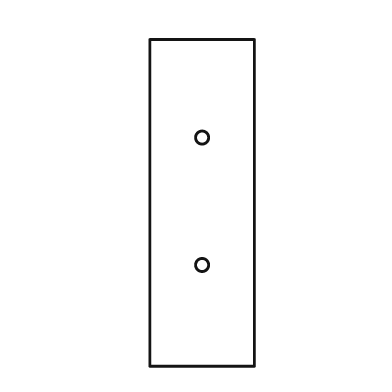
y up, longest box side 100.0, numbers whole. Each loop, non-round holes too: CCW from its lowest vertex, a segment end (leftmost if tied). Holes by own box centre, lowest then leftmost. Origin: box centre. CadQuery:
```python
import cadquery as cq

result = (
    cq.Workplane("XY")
    .moveTo(-16.0, -50.0)
    .lineTo(16.0, -50.0)
    .lineTo(16.0, 50.0)
    .lineTo(-16.0, 50.0)
    .close()
    .moveTo(0.0, -19.0)
    .circle(2.0)
    .moveTo(0.0, 20.0)
    .circle(2.0)
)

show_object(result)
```